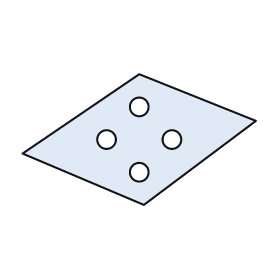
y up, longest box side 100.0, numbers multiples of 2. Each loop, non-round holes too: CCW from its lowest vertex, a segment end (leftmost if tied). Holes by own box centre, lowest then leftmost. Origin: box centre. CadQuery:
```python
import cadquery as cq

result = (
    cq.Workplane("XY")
    .moveTo(2.0, -28.0)
    .lineTo(50.0, 8.0)
    .lineTo(0.0, 28.0)
    .lineTo(-50.0, -6.0)
    .close()
    .moveTo(0.0, -14.0)
    .circle(4.0)
    .moveTo(-14.0, 0.0)
    .circle(4.0)
    .moveTo(14.0, 0.0)
    .circle(4.0)
    .moveTo(0.0, 14.0)
    .circle(4.0)
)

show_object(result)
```